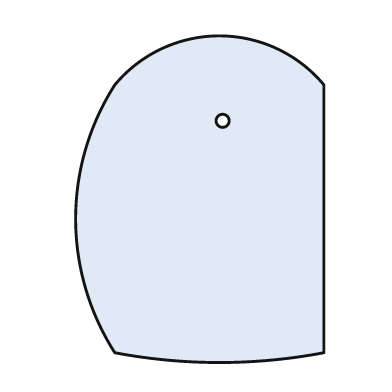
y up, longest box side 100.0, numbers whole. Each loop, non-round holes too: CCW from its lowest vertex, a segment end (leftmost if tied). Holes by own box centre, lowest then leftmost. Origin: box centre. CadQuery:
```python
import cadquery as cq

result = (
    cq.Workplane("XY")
    .moveTo(-26.0, -47.0)
    .threePointArc((6.0, -50.0), (38.0, -47.0))
    .lineTo(38.0, 35.0)
    .threePointArc((6.0, 50.0), (-26.0, 35.0))
    .threePointArc((-38.0, -6.0), (-26.0, -47.0))
    .close()
    .moveTo(7.0, 24.0)
    .circle(2.0)
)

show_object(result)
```